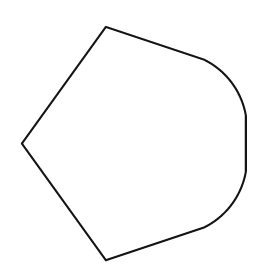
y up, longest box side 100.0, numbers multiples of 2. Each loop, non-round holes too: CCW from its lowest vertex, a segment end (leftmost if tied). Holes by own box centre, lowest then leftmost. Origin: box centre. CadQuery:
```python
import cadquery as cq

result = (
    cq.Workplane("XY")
    .moveTo(-12.0, -50.0)
    .lineTo(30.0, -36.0)
    .threePointArc((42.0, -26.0), (48.0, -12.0))
    .lineTo(48.0, 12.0)
    .threePointArc((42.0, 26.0), (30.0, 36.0))
    .lineTo(-12.0, 50.0)
    .lineTo(-48.0, 0.0)
    .close()
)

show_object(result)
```